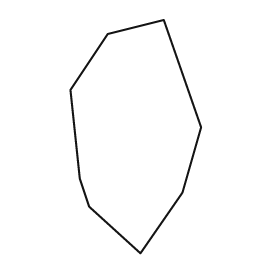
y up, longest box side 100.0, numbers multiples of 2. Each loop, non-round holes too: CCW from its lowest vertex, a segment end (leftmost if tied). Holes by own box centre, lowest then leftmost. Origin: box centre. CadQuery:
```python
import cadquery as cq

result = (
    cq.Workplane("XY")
    .moveTo(2.0, -50.0)
    .lineTo(20.0, -24.0)
    .lineTo(28.0, 4.0)
    .lineTo(12.0, 50.0)
    .lineTo(-12.0, 44.0)
    .lineTo(-28.0, 20.0)
    .lineTo(-24.0, -18.0)
    .lineTo(-20.0, -30.0)
    .close()
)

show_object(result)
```